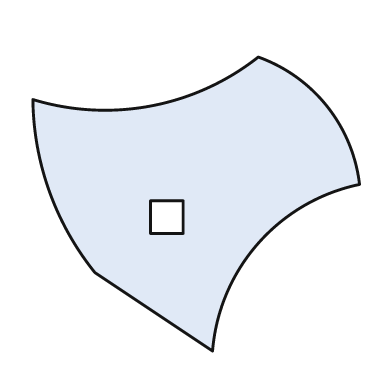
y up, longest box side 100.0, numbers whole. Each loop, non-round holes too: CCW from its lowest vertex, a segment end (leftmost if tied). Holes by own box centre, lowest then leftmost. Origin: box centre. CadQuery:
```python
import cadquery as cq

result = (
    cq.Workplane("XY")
    .moveTo(5.0, -45.0)
    .threePointArc((19.0, -12.0), (50.0, 6.0))
    .threePointArc((40.0, 30.0), (19.0, 45.0))
    .threePointArc((-14.0, 30.0), (-50.0, 32.0))
    .threePointArc((-45.0, 4.0), (-31.0, -21.0))
    .close()
    .moveTo(-14.0, -9.0)
    .lineTo(-4.0, -9.0)
    .lineTo(-4.0, 1.0)
    .lineTo(-14.0, 1.0)
    .close()
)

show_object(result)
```